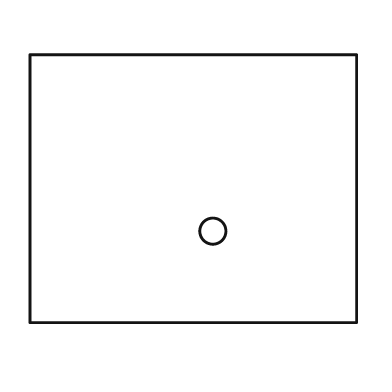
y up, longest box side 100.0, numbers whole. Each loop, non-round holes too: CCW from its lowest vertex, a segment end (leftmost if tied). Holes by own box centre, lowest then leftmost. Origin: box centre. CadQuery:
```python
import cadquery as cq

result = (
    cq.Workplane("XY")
    .moveTo(-50.0, -41.0)
    .lineTo(50.0, -41.0)
    .lineTo(50.0, 41.0)
    .lineTo(-50.0, 41.0)
    .close()
    .moveTo(6.0, -13.0)
    .circle(4.0)
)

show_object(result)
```